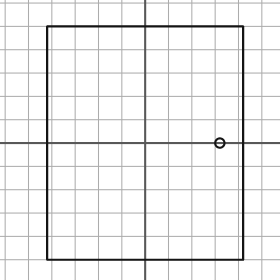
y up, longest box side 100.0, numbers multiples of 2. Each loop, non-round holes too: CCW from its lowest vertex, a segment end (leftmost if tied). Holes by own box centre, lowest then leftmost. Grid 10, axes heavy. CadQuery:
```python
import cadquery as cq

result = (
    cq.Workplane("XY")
    .moveTo(-42.0, -50.0)
    .lineTo(42.0, -50.0)
    .lineTo(42.0, 50.0)
    .lineTo(-42.0, 50.0)
    .close()
    .moveTo(32.0, 0.0)
    .circle(2.0)
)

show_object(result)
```